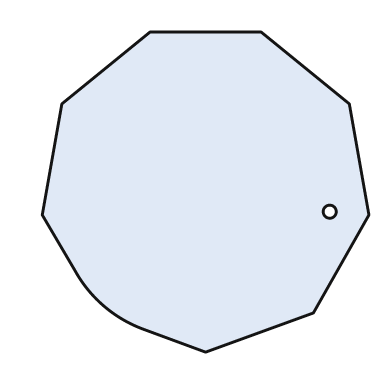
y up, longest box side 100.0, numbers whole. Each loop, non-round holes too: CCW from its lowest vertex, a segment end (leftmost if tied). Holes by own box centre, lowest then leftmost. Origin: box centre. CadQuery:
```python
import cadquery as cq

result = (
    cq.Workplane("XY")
    .moveTo(0.0, -49.0)
    .lineTo(33.0, -37.0)
    .lineTo(50.0, -7.0)
    .lineTo(44.0, 27.0)
    .lineTo(17.0, 49.0)
    .lineTo(-17.0, 49.0)
    .lineTo(-44.0, 27.0)
    .lineTo(-50.0, -7.0)
    .lineTo(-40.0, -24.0)
    .threePointArc((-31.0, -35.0), (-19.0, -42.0))
    .close()
    .moveTo(38.0, -6.0)
    .circle(2.0)
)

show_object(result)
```